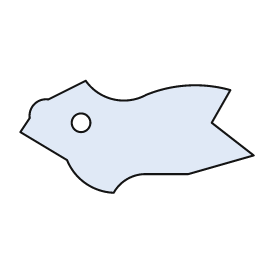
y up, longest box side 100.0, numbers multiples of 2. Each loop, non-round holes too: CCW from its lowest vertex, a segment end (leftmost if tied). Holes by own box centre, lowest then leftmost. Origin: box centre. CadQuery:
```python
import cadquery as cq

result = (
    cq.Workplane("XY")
    .moveTo(-10.0, -24.0)
    .threePointArc((-4.0, -18.0), (4.0, -16.0))
    .lineTo(22.0, -16.0)
    .lineTo(50.0, -8.0)
    .lineTo(32.0, 6.0)
    .lineTo(40.0, 20.0)
    .threePointArc((22.0, 22.0), (4.0, 18.0))
    .threePointArc((-10.0, 16.0), (-22.0, 24.0))
    .lineTo(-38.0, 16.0)
    .threePointArc((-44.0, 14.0), (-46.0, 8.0))
    .lineTo(-50.0, 2.0)
    .lineTo(-30.0, -10.0)
    .threePointArc((-22.0, -20.0), (-10.0, -24.0))
    .close()
    .moveTo(-24.0, 6.0)
    .circle(4.0)
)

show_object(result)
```